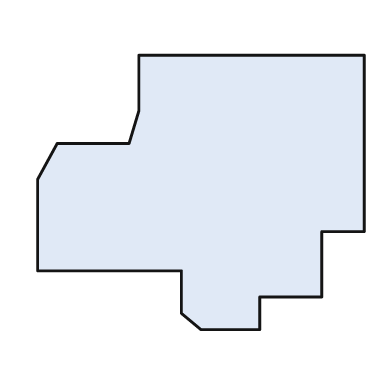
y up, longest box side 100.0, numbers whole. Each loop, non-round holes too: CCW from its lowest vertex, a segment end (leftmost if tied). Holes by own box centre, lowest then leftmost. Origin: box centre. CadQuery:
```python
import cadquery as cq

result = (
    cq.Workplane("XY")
    .moveTo(0.0, -42.0)
    .lineTo(18.0, -42.0)
    .lineTo(18.0, -32.0)
    .lineTo(37.0, -32.0)
    .lineTo(37.0, -12.0)
    .lineTo(50.0, -12.0)
    .lineTo(50.0, 42.0)
    .lineTo(-19.0, 42.0)
    .lineTo(-19.0, 25.0)
    .lineTo(-22.0, 15.0)
    .lineTo(-44.0, 15.0)
    .lineTo(-50.0, 4.0)
    .lineTo(-50.0, -24.0)
    .lineTo(-6.0, -24.0)
    .lineTo(-6.0, -37.0)
    .close()
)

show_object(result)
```